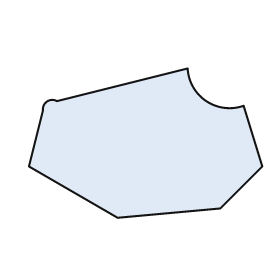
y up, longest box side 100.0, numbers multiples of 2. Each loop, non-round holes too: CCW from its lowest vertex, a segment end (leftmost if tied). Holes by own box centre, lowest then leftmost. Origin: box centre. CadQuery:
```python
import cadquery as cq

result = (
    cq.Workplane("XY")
    .moveTo(-12.0, -32.0)
    .lineTo(32.0, -28.0)
    .lineTo(50.0, -10.0)
    .lineTo(42.0, 16.0)
    .threePointArc((26.0, 18.0), (18.0, 32.0))
    .lineTo(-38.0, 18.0)
    .threePointArc((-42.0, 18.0), (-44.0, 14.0))
    .lineTo(-50.0, -10.0)
    .close()
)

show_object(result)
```